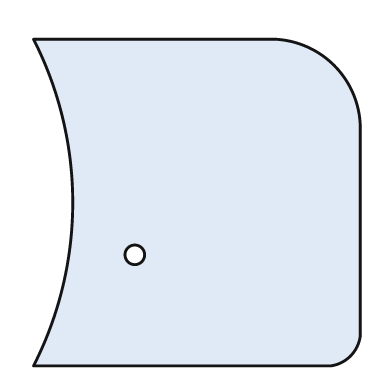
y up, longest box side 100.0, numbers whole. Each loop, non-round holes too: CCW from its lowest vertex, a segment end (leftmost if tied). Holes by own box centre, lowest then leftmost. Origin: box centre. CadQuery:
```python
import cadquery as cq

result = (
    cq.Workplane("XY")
    .moveTo(-50.0, -50.0)
    .lineTo(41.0, -50.0)
    .threePointArc((47.0, -47.0), (50.0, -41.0))
    .lineTo(50.0, 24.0)
    .threePointArc((42.0, 42.0), (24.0, 50.0))
    .lineTo(-50.0, 50.0)
    .threePointArc((-38.0, 0.0), (-50.0, -50.0))
    .close()
    .moveTo(-19.0, -16.0)
    .circle(3.0)
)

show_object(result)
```